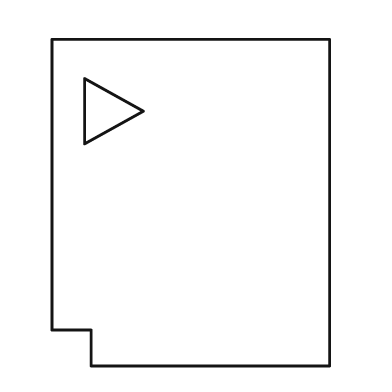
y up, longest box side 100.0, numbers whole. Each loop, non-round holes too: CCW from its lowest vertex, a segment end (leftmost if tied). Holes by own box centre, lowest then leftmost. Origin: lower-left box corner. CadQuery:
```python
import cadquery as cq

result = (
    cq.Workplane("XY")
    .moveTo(12.0, 0.0)
    .lineTo(85.0, 0.0)
    .lineTo(85.0, 100.0)
    .lineTo(0.0, 100.0)
    .lineTo(0.0, 11.0)
    .lineTo(12.0, 11.0)
    .close()
    .moveTo(10.0, 68.0)
    .lineTo(28.0, 78.0)
    .lineTo(10.0, 88.0)
    .close()
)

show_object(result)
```